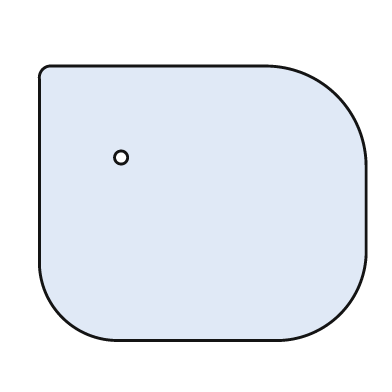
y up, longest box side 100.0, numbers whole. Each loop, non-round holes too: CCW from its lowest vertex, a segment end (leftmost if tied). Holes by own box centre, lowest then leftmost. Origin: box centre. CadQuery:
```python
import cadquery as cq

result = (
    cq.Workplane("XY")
    .moveTo(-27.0, -42.0)
    .lineTo(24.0, -42.0)
    .threePointArc((42.0, -34.0), (50.0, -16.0))
    .lineTo(50.0, 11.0)
    .threePointArc((41.0, 33.0), (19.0, 42.0))
    .lineTo(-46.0, 42.0)
    .threePointArc((-49.0, 41.0), (-50.0, 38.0))
    .lineTo(-50.0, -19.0)
    .threePointArc((-43.0, -35.0), (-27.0, -42.0))
    .close()
    .moveTo(-25.0, 14.0)
    .circle(2.0)
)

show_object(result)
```